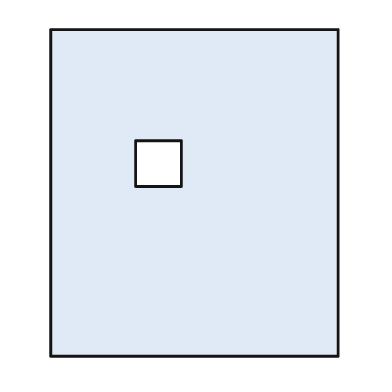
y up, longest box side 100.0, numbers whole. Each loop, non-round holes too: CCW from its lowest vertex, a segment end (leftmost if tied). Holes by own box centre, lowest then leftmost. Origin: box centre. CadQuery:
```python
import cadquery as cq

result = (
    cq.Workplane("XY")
    .moveTo(-44.0, -50.0)
    .lineTo(44.0, -50.0)
    .lineTo(44.0, 50.0)
    .lineTo(-44.0, 50.0)
    .close()
    .moveTo(-18.0, 2.0)
    .lineTo(-4.0, 2.0)
    .lineTo(-4.0, 16.0)
    .lineTo(-18.0, 16.0)
    .close()
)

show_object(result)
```